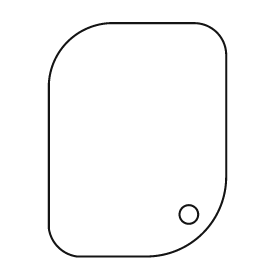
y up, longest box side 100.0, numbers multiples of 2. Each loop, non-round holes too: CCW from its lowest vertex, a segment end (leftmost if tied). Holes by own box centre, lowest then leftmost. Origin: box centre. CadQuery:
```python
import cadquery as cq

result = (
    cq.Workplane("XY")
    .moveTo(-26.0, -50.0)
    .lineTo(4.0, -50.0)
    .threePointArc((28.0, -40.0), (38.0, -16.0))
    .lineTo(38.0, 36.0)
    .threePointArc((34.0, 46.0), (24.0, 50.0))
    .lineTo(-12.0, 50.0)
    .threePointArc((-30.0, 42.0), (-38.0, 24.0))
    .lineTo(-38.0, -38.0)
    .threePointArc((-34.0, -46.0), (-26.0, -50.0))
    .close()
    .moveTo(22.0, -32.0)
    .circle(4.0)
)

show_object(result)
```